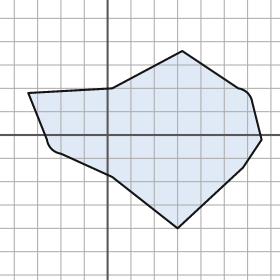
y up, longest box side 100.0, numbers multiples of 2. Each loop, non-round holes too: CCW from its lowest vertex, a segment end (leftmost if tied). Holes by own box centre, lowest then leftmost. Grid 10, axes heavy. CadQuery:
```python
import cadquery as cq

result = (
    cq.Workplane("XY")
    .moveTo(30.0, -40.0)
    .lineTo(58.0, -14.0)
    .lineTo(66.0, -2.0)
    .lineTo(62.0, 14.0)
    .threePointArc((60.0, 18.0), (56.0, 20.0))
    .lineTo(32.0, 36.0)
    .lineTo(2.0, 20.0)
    .lineTo(-34.0, 18.0)
    .lineTo(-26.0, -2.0)
    .threePointArc((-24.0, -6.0), (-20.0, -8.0))
    .lineTo(2.0, -18.0)
    .close()
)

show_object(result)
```